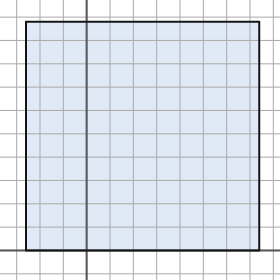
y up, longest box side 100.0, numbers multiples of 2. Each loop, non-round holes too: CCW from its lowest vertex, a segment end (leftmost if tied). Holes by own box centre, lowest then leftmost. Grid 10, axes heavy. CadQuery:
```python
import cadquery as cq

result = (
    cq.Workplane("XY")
    .moveTo(-26.0, 0.0)
    .lineTo(74.0, 0.0)
    .lineTo(74.0, 98.0)
    .lineTo(-26.0, 98.0)
    .close()
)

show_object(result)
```